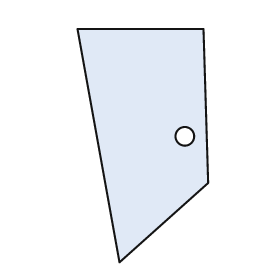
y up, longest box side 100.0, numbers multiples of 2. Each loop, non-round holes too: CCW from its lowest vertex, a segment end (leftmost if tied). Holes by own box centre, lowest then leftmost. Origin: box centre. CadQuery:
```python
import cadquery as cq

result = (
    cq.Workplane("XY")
    .moveTo(-10.0, -50.0)
    .lineTo(28.0, -16.0)
    .lineTo(26.0, 50.0)
    .lineTo(-28.0, 50.0)
    .close()
    .moveTo(18.0, 4.0)
    .circle(4.0)
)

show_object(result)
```